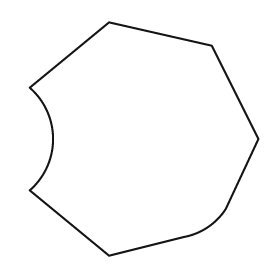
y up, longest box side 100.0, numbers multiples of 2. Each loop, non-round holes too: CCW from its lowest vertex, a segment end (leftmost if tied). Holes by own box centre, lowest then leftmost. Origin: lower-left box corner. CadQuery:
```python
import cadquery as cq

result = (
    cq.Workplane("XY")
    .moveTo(34.0, 0.0)
    .lineTo(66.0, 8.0)
    .threePointArc((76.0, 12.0), (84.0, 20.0))
    .lineTo(98.0, 50.0)
    .lineTo(78.0, 90.0)
    .lineTo(34.0, 100.0)
    .lineTo(0.0, 72.0)
    .threePointArc((10.0, 50.0), (0.0, 28.0))
    .close()
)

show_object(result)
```